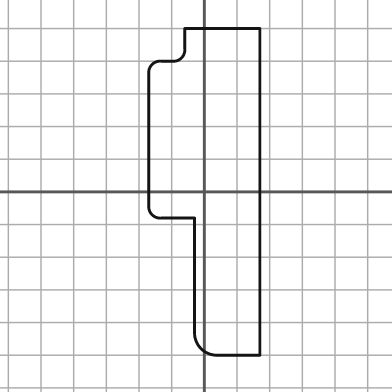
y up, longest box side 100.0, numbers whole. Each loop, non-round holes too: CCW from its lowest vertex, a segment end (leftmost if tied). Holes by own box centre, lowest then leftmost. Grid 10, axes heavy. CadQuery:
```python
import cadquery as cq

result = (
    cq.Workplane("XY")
    .moveTo(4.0, -50.0)
    .lineTo(17.0, -50.0)
    .lineTo(17.0, 50.0)
    .lineTo(-6.0, 50.0)
    .lineTo(-6.0, 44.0)
    .threePointArc((-7.0, 41.0), (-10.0, 40.0))
    .lineTo(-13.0, 40.0)
    .threePointArc((-16.0, 39.0), (-17.0, 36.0))
    .lineTo(-17.0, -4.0)
    .threePointArc((-16.0, -7.0), (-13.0, -8.0))
    .lineTo(-3.0, -8.0)
    .lineTo(-3.0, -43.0)
    .threePointArc((-1.0, -48.0), (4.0, -50.0))
    .close()
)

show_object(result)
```